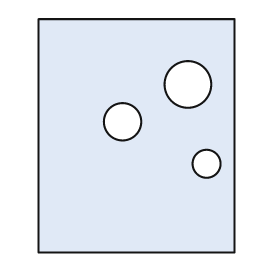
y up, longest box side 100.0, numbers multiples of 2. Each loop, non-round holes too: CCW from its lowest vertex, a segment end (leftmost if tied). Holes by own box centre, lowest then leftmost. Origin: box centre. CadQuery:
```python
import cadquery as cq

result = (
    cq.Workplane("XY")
    .moveTo(-42.0, -50.0)
    .lineTo(42.0, -50.0)
    .lineTo(42.0, 50.0)
    .lineTo(-42.0, 50.0)
    .close()
    .moveTo(30.0, -12.0)
    .circle(6.0)
    .moveTo(-6.0, 6.0)
    .circle(8.0)
    .moveTo(22.0, 22.0)
    .circle(10.0)
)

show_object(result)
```